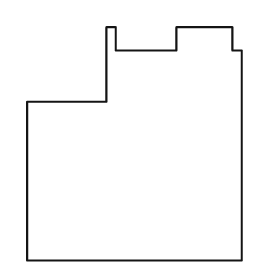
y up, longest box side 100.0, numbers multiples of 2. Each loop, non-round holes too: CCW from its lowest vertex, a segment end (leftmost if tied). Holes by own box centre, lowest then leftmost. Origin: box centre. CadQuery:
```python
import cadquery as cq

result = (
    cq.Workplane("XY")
    .moveTo(-46.0, -50.0)
    .lineTo(46.0, -50.0)
    .lineTo(46.0, 40.0)
    .lineTo(42.0, 40.0)
    .lineTo(42.0, 50.0)
    .lineTo(18.0, 50.0)
    .lineTo(18.0, 40.0)
    .lineTo(-8.0, 40.0)
    .lineTo(-8.0, 50.0)
    .lineTo(-12.0, 50.0)
    .lineTo(-12.0, 18.0)
    .lineTo(-46.0, 18.0)
    .close()
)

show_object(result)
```